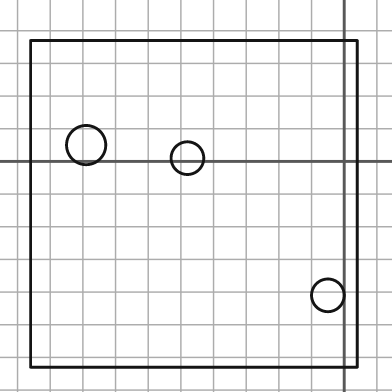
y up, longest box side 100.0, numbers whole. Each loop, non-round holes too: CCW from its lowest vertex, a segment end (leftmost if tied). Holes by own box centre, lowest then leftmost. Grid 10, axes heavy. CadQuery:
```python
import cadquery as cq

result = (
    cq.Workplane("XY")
    .moveTo(-96.0, -63.0)
    .lineTo(4.0, -63.0)
    .lineTo(4.0, 37.0)
    .lineTo(-96.0, 37.0)
    .close()
    .moveTo(-5.0, -41.0)
    .circle(5.0)
    .moveTo(-48.0, 1.0)
    .circle(5.0)
    .moveTo(-79.0, 5.0)
    .circle(6.0)
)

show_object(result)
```